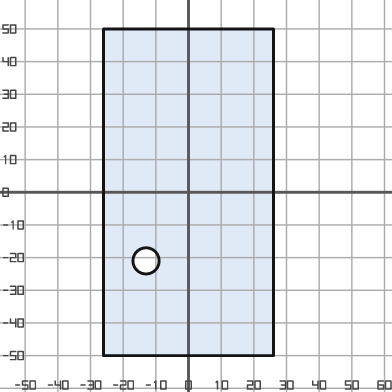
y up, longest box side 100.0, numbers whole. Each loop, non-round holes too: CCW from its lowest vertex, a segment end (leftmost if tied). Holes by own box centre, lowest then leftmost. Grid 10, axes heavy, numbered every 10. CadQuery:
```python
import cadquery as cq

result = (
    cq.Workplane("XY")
    .moveTo(-26.0, -50.0)
    .lineTo(26.0, -50.0)
    .lineTo(26.0, 50.0)
    .lineTo(-26.0, 50.0)
    .close()
    .moveTo(-13.0, -21.0)
    .circle(4.0)
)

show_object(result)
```